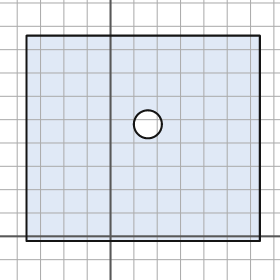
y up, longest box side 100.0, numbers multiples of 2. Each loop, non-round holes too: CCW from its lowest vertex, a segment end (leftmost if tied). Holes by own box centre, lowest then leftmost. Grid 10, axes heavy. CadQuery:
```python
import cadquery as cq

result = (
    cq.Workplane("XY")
    .moveTo(-36.0, -2.0)
    .lineTo(64.0, -2.0)
    .lineTo(64.0, 86.0)
    .lineTo(-36.0, 86.0)
    .close()
    .moveTo(16.0, 48.0)
    .circle(6.0)
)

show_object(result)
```